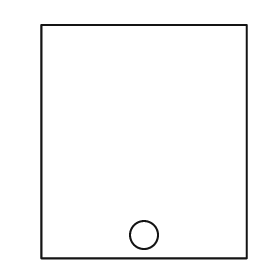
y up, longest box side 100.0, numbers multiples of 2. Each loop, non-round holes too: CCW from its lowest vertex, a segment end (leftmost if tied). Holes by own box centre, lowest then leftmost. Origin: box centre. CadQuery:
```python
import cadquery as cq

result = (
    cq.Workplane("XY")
    .moveTo(-44.0, -50.0)
    .lineTo(44.0, -50.0)
    .lineTo(44.0, 50.0)
    .lineTo(-44.0, 50.0)
    .close()
    .moveTo(0.0, -40.0)
    .circle(6.0)
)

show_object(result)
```